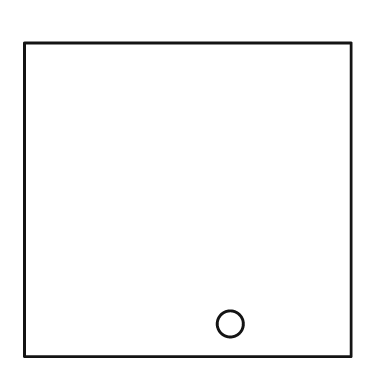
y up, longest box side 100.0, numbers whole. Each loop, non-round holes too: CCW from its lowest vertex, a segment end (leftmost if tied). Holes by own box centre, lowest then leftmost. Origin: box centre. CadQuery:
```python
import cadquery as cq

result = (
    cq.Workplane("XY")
    .moveTo(-50.0, -48.0)
    .lineTo(50.0, -48.0)
    .lineTo(50.0, 48.0)
    .lineTo(-50.0, 48.0)
    .close()
    .moveTo(13.0, -38.0)
    .circle(4.0)
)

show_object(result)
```